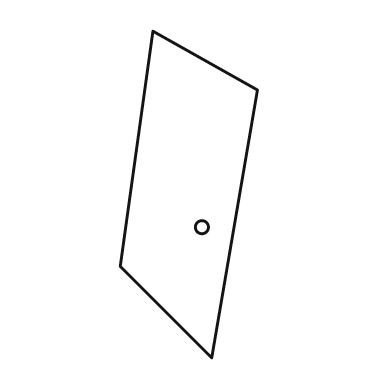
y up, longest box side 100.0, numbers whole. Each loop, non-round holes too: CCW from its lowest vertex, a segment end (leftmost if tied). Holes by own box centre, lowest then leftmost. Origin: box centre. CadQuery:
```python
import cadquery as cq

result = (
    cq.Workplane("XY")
    .moveTo(7.0, -50.0)
    .lineTo(21.0, 32.0)
    .lineTo(-11.0, 50.0)
    .lineTo(-21.0, -22.0)
    .close()
    .moveTo(4.0, -10.0)
    .circle(2.0)
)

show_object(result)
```